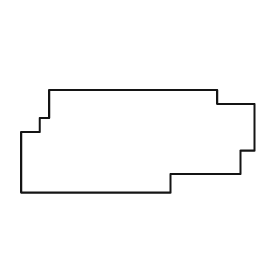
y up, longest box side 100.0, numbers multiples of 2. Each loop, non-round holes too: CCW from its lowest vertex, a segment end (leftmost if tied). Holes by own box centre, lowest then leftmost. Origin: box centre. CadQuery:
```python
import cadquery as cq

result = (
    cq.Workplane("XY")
    .moveTo(-50.0, -22.0)
    .lineTo(14.0, -22.0)
    .lineTo(14.0, -14.0)
    .lineTo(44.0, -14.0)
    .lineTo(44.0, -4.0)
    .lineTo(50.0, -4.0)
    .lineTo(50.0, 16.0)
    .lineTo(34.0, 16.0)
    .lineTo(34.0, 22.0)
    .lineTo(-38.0, 22.0)
    .lineTo(-38.0, 10.0)
    .lineTo(-42.0, 10.0)
    .lineTo(-42.0, 4.0)
    .lineTo(-50.0, 4.0)
    .close()
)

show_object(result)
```